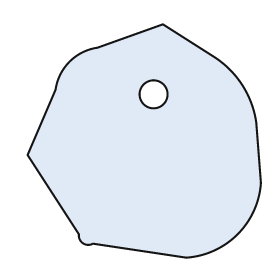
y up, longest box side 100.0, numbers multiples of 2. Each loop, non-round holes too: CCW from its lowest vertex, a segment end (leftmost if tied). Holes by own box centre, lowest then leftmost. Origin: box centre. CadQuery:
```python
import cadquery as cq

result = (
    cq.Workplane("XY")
    .moveTo(18.0, -50.0)
    .threePointArc((40.0, -40.0), (50.0, -18.0))
    .lineTo(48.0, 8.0)
    .threePointArc((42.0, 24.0), (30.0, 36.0))
    .lineTo(8.0, 50.0)
    .lineTo(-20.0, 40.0)
    .threePointArc((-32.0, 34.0), (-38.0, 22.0))
    .lineTo(-50.0, -6.0)
    .lineTo(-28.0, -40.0)
    .threePointArc((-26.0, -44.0), (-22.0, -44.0))
    .close()
    .moveTo(4.0, 20.0)
    .circle(6.0)
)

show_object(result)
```